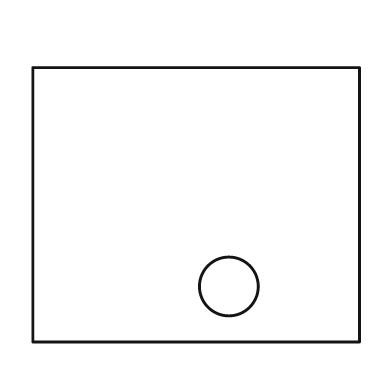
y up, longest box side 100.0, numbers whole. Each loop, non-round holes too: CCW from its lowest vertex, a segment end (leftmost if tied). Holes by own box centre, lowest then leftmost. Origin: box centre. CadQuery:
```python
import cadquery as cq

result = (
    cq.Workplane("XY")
    .moveTo(-50.0, -42.0)
    .lineTo(50.0, -42.0)
    .lineTo(50.0, 42.0)
    .lineTo(-50.0, 42.0)
    .close()
    .moveTo(10.0, -25.0)
    .circle(9.0)
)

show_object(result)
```